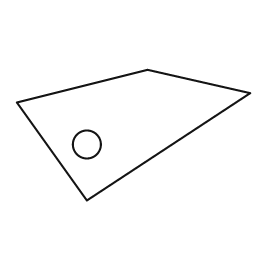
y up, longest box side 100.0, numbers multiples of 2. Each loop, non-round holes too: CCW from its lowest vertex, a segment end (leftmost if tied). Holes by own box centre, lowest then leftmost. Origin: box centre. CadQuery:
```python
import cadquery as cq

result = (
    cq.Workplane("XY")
    .moveTo(-20.0, -28.0)
    .lineTo(50.0, 18.0)
    .lineTo(6.0, 28.0)
    .lineTo(-50.0, 14.0)
    .close()
    .moveTo(-20.0, -4.0)
    .circle(6.0)
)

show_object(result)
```